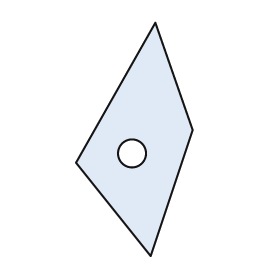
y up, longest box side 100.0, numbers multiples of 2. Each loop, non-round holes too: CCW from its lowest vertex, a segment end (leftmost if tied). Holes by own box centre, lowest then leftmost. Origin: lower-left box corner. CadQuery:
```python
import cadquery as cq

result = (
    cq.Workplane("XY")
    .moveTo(32.0, 0.0)
    .lineTo(50.0, 54.0)
    .lineTo(34.0, 100.0)
    .lineTo(0.0, 40.0)
    .close()
    .moveTo(24.0, 44.0)
    .circle(6.0)
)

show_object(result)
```